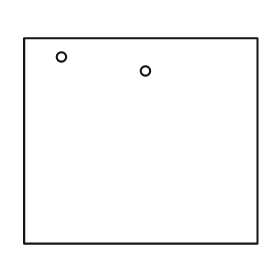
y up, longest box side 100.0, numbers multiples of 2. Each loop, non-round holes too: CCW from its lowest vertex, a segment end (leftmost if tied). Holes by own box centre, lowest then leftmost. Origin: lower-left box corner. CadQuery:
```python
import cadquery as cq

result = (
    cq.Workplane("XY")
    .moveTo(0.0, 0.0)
    .lineTo(100.0, 0.0)
    .lineTo(100.0, 88.0)
    .lineTo(0.0, 88.0)
    .close()
    .moveTo(52.0, 74.0)
    .circle(2.0)
    .moveTo(16.0, 80.0)
    .circle(2.0)
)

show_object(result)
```